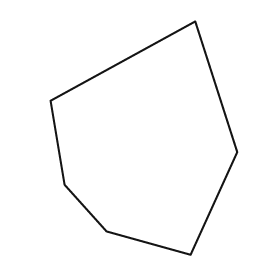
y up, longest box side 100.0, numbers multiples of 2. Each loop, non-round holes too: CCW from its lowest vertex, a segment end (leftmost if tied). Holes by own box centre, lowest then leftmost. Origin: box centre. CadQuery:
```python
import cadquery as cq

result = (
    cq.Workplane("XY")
    .moveTo(20.0, -50.0)
    .lineTo(40.0, -6.0)
    .lineTo(22.0, 50.0)
    .lineTo(-40.0, 16.0)
    .lineTo(-34.0, -20.0)
    .lineTo(-16.0, -40.0)
    .close()
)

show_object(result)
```